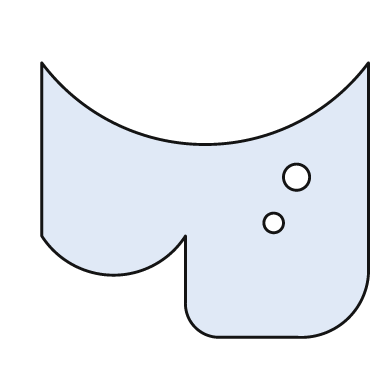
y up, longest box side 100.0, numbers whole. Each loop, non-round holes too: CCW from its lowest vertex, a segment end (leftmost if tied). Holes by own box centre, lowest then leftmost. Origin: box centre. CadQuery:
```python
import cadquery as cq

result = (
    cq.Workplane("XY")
    .moveTo(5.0, -42.0)
    .lineTo(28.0, -42.0)
    .threePointArc((44.0, -36.0), (50.0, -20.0))
    .lineTo(50.0, 42.0)
    .threePointArc((0.0, 17.0), (-50.0, 42.0))
    .lineTo(-50.0, -11.0)
    .threePointArc((-28.0, -23.0), (-6.0, -11.0))
    .lineTo(-6.0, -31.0)
    .threePointArc((-3.0, -39.0), (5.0, -42.0))
    .close()
    .moveTo(21.0, -7.0)
    .circle(3.0)
    .moveTo(28.0, 7.0)
    .circle(4.0)
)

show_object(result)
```